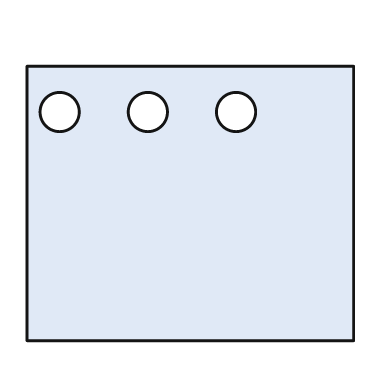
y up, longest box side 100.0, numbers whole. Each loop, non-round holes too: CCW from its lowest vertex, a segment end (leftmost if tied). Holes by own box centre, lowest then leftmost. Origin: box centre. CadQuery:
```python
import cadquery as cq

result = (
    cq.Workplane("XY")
    .moveTo(-50.0, -42.0)
    .lineTo(50.0, -42.0)
    .lineTo(50.0, 42.0)
    .lineTo(-50.0, 42.0)
    .close()
    .moveTo(-40.0, 28.0)
    .circle(6.0)
    .moveTo(-13.0, 28.0)
    .circle(6.0)
    .moveTo(14.0, 28.0)
    .circle(6.0)
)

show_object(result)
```